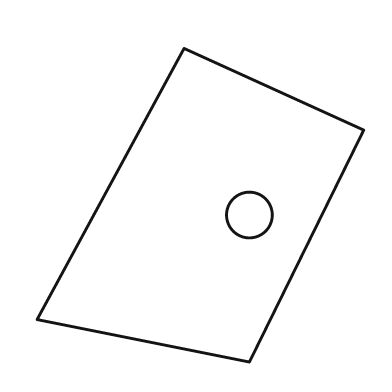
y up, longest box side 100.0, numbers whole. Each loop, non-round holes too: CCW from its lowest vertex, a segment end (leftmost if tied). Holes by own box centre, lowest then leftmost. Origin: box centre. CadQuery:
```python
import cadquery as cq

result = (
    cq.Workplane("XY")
    .moveTo(15.0, -48.0)
    .lineTo(50.0, 23.0)
    .lineTo(-5.0, 48.0)
    .lineTo(-50.0, -35.0)
    .close()
    .moveTo(15.0, -3.0)
    .circle(7.0)
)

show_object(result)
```